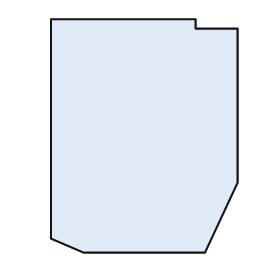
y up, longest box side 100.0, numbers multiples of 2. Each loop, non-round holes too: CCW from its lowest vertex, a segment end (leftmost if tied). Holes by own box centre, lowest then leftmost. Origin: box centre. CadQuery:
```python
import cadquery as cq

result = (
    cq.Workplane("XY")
    .moveTo(-26.0, -50.0)
    .lineTo(26.0, -50.0)
    .lineTo(40.0, -20.0)
    .lineTo(40.0, 46.0)
    .lineTo(22.0, 46.0)
    .lineTo(22.0, 50.0)
    .lineTo(-40.0, 50.0)
    .lineTo(-40.0, -44.0)
    .close()
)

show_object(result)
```